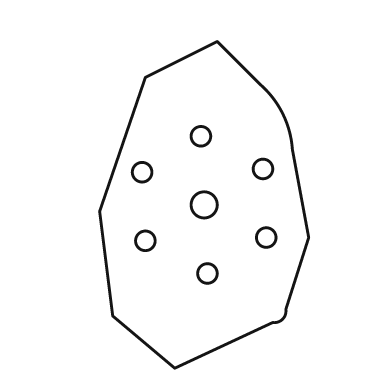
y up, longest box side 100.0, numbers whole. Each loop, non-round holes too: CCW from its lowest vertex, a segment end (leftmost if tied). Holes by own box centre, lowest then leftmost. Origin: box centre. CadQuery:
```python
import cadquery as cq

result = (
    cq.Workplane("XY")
    .moveTo(-9.0, -50.0)
    .lineTo(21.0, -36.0)
    .threePointArc((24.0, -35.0), (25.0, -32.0))
    .lineTo(32.0, -10.0)
    .lineTo(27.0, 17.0)
    .threePointArc((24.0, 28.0), (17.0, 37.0))
    .lineTo(4.0, 50.0)
    .lineTo(-18.0, 39.0)
    .lineTo(-32.0, -2.0)
    .lineTo(-28.0, -34.0)
    .close()
    .moveTo(1.0, -21.0)
    .circle(3.0)
    .moveTo(-18.0, -11.0)
    .circle(3.0)
    .moveTo(19.0, -10.0)
    .circle(3.0)
    .moveTo(0.0, 0.0)
    .circle(4.0)
    .moveTo(-19.0, 10.0)
    .circle(3.0)
    .moveTo(18.0, 11.0)
    .circle(3.0)
    .moveTo(-1.0, 21.0)
    .circle(3.0)
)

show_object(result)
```